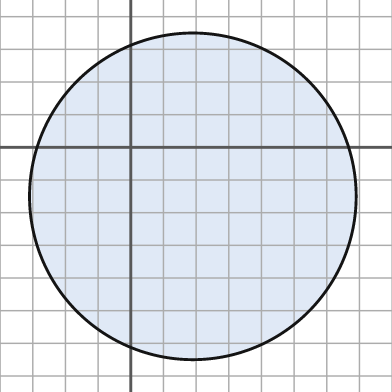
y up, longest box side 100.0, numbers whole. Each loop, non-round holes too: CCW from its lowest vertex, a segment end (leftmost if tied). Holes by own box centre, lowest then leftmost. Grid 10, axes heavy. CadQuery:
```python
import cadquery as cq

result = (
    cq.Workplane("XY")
    .moveTo(19.0, -15.0)
    .circle(50.0)
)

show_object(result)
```